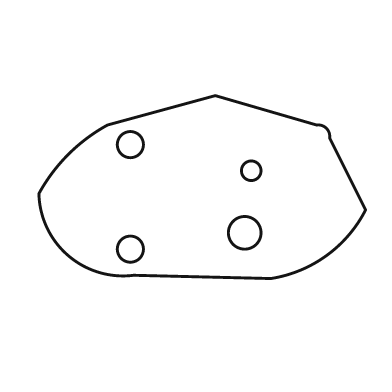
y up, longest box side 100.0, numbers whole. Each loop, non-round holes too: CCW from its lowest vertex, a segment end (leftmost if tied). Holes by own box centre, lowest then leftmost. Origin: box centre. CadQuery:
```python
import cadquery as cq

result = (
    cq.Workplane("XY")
    .moveTo(21.0, -28.0)
    .threePointArc((38.0, -21.0), (50.0, -7.0))
    .lineTo(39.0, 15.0)
    .threePointArc((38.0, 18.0), (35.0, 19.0))
    .lineTo(4.0, 28.0)
    .lineTo(-29.0, 19.0)
    .threePointArc((-41.0, 10.0), (-50.0, -2.0))
    .threePointArc((-41.0, -21.0), (-21.0, -27.0))
    .close()
    .moveTo(-22.0, -19.0)
    .circle(4.0)
    .moveTo(13.0, -14.0)
    .circle(5.0)
    .moveTo(15.0, 5.0)
    .circle(3.0)
    .moveTo(-22.0, 13.0)
    .circle(4.0)
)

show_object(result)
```